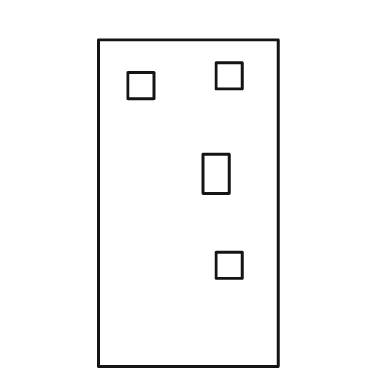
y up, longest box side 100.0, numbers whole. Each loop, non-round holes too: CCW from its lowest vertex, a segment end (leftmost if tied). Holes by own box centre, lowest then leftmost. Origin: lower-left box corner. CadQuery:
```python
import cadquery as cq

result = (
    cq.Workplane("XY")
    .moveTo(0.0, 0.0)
    .lineTo(55.0, 0.0)
    .lineTo(55.0, 100.0)
    .lineTo(0.0, 100.0)
    .close()
    .moveTo(36.0, 27.0)
    .lineTo(44.0, 27.0)
    .lineTo(44.0, 35.0)
    .lineTo(36.0, 35.0)
    .close()
    .moveTo(32.0, 53.0)
    .lineTo(40.0, 53.0)
    .lineTo(40.0, 65.0)
    .lineTo(32.0, 65.0)
    .close()
    .moveTo(9.0, 82.0)
    .lineTo(17.0, 82.0)
    .lineTo(17.0, 90.0)
    .lineTo(9.0, 90.0)
    .close()
    .moveTo(36.0, 85.0)
    .lineTo(44.0, 85.0)
    .lineTo(44.0, 93.0)
    .lineTo(36.0, 93.0)
    .close()
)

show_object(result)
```